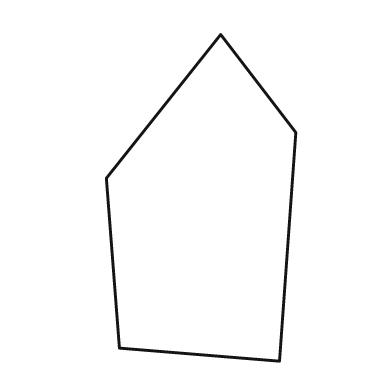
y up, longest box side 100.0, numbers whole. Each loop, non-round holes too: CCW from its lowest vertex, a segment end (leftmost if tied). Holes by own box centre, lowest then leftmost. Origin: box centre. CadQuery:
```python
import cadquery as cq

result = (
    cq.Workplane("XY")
    .moveTo(24.0, -50.0)
    .lineTo(29.0, 20.0)
    .lineTo(6.0, 50.0)
    .lineTo(-29.0, 6.0)
    .lineTo(-25.0, -46.0)
    .close()
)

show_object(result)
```